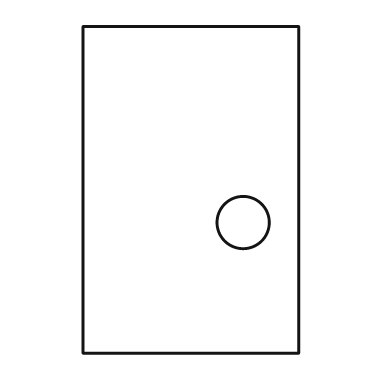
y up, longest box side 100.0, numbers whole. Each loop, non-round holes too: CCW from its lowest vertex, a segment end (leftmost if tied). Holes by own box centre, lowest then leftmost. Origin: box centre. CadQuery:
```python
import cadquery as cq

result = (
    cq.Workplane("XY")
    .moveTo(-33.0, -50.0)
    .lineTo(33.0, -50.0)
    .lineTo(33.0, 50.0)
    .lineTo(-33.0, 50.0)
    .close()
    .moveTo(16.0, -10.0)
    .circle(8.0)
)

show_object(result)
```